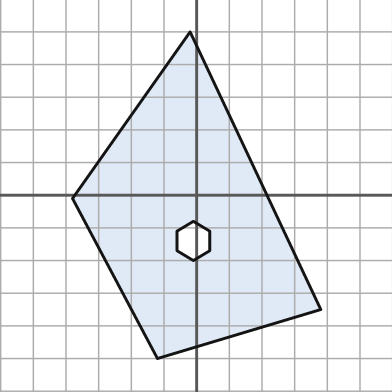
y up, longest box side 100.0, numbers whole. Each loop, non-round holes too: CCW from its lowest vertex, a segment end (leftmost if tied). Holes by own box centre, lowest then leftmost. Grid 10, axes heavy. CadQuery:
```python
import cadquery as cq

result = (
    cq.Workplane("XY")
    .moveTo(-12.0, -50.0)
    .lineTo(38.0, -35.0)
    .lineTo(-2.0, 50.0)
    .lineTo(-38.0, -1.0)
    .close()
    .moveTo(-1.0, -20.0)
    .lineTo(4.0, -17.0)
    .lineTo(4.0, -11.0)
    .lineTo(-1.0, -8.0)
    .lineTo(-6.0, -11.0)
    .lineTo(-6.0, -17.0)
    .close()
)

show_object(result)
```